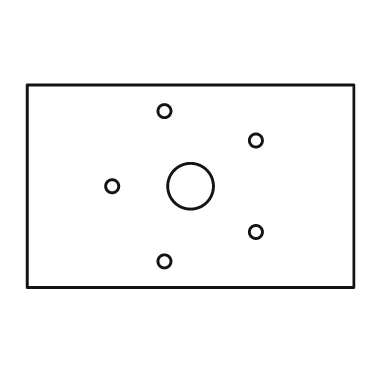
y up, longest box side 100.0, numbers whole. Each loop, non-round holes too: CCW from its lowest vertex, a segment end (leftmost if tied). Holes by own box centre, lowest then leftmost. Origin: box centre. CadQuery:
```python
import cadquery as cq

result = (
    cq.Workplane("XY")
    .moveTo(-50.0, -31.0)
    .lineTo(50.0, -31.0)
    .lineTo(50.0, 31.0)
    .lineTo(-50.0, 31.0)
    .close()
    .moveTo(-8.0, -23.0)
    .circle(2.0)
    .moveTo(20.0, -14.0)
    .circle(2.0)
    .moveTo(-24.0, 0.0)
    .circle(2.0)
    .moveTo(0.0, 0.0)
    .circle(7.0)
    .moveTo(20.0, 14.0)
    .circle(2.0)
    .moveTo(-8.0, 23.0)
    .circle(2.0)
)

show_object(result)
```